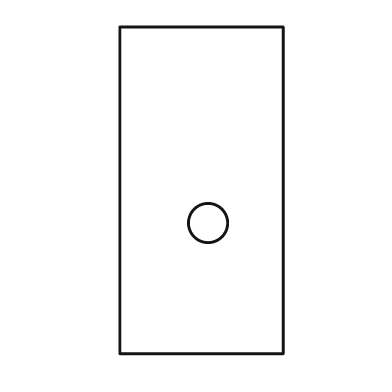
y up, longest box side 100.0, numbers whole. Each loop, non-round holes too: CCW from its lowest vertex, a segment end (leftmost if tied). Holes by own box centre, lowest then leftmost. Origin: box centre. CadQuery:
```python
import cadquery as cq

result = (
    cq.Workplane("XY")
    .moveTo(-25.0, -50.0)
    .lineTo(25.0, -50.0)
    .lineTo(25.0, 50.0)
    .lineTo(-25.0, 50.0)
    .close()
    .moveTo(2.0, -10.0)
    .circle(6.0)
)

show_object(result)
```